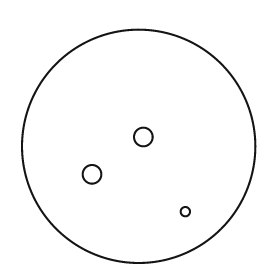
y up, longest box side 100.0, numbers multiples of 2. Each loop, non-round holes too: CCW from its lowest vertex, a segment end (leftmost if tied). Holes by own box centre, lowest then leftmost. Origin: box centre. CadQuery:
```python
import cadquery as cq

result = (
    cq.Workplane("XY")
    .moveTo(0.0, 0.0)
    .circle(50.0)
    .moveTo(20.0, -28.0)
    .circle(2.0)
    .moveTo(-20.0, -12.0)
    .circle(4.0)
    .moveTo(2.0, 4.0)
    .circle(4.0)
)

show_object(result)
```